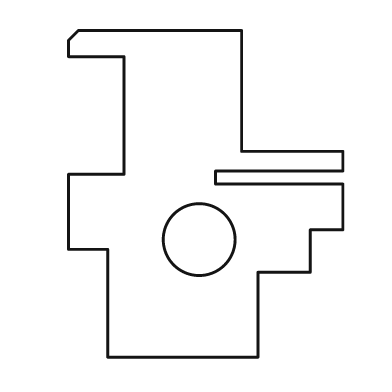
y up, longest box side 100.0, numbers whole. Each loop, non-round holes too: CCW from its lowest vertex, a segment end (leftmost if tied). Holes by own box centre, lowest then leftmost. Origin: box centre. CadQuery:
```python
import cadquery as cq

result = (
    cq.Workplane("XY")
    .moveTo(-30.0, -50.0)
    .lineTo(16.0, -50.0)
    .lineTo(16.0, -24.0)
    .lineTo(32.0, -24.0)
    .lineTo(32.0, -11.0)
    .lineTo(42.0, -11.0)
    .lineTo(42.0, 3.0)
    .lineTo(3.0, 3.0)
    .lineTo(3.0, 7.0)
    .lineTo(42.0, 7.0)
    .lineTo(42.0, 13.0)
    .lineTo(11.0, 13.0)
    .lineTo(11.0, 50.0)
    .lineTo(-39.0, 50.0)
    .lineTo(-42.0, 47.0)
    .lineTo(-42.0, 42.0)
    .lineTo(-25.0, 42.0)
    .lineTo(-25.0, 6.0)
    .lineTo(-42.0, 6.0)
    .lineTo(-42.0, -17.0)
    .lineTo(-30.0, -17.0)
    .close()
    .moveTo(-2.0, -14.0)
    .circle(11.0)
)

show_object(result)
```